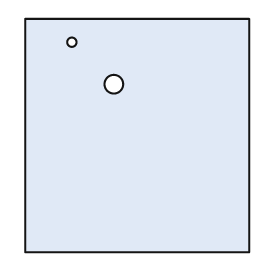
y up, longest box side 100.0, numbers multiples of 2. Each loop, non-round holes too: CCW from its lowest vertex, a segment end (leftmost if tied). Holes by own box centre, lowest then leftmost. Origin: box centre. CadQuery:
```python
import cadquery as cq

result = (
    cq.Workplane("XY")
    .moveTo(-48.0, -50.0)
    .lineTo(48.0, -50.0)
    .lineTo(48.0, 50.0)
    .lineTo(-48.0, 50.0)
    .close()
    .moveTo(-10.0, 22.0)
    .circle(4.0)
    .moveTo(-28.0, 40.0)
    .circle(2.0)
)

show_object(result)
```